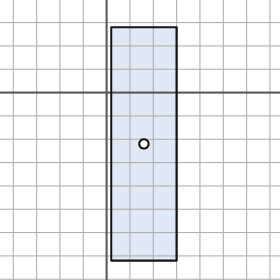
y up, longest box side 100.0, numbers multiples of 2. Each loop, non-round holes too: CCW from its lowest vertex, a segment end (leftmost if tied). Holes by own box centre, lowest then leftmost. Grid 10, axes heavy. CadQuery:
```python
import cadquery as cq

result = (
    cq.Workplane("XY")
    .moveTo(2.0, -72.0)
    .lineTo(30.0, -72.0)
    .lineTo(30.0, 28.0)
    .lineTo(2.0, 28.0)
    .close()
    .moveTo(16.0, -22.0)
    .circle(2.0)
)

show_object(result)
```